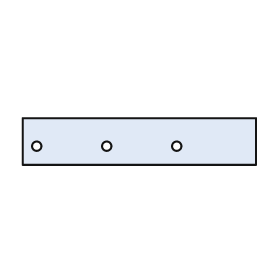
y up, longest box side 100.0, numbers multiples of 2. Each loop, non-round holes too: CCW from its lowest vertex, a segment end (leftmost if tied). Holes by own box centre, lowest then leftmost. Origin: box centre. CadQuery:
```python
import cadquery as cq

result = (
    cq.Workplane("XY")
    .moveTo(-50.0, -10.0)
    .lineTo(50.0, -10.0)
    .lineTo(50.0, 10.0)
    .lineTo(-50.0, 10.0)
    .close()
    .moveTo(-44.0, -2.0)
    .circle(2.0)
    .moveTo(-14.0, -2.0)
    .circle(2.0)
    .moveTo(16.0, -2.0)
    .circle(2.0)
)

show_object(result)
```